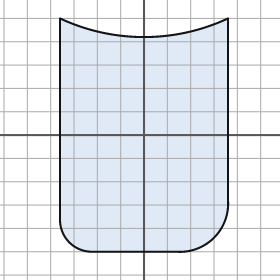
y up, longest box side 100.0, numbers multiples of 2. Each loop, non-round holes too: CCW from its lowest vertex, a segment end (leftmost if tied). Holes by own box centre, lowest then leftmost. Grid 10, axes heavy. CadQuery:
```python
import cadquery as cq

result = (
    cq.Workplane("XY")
    .moveTo(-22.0, -50.0)
    .lineTo(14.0, -50.0)
    .threePointArc((30.0, -44.0), (36.0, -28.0))
    .lineTo(36.0, 50.0)
    .threePointArc((0.0, 42.0), (-36.0, 50.0))
    .lineTo(-36.0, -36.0)
    .threePointArc((-32.0, -46.0), (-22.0, -50.0))
    .close()
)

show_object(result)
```